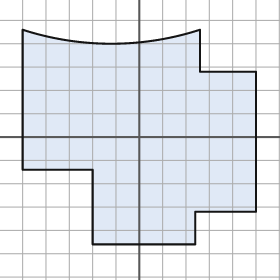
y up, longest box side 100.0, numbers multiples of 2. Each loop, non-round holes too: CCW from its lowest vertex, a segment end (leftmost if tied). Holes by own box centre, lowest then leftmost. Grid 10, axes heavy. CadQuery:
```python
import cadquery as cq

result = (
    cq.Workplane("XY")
    .moveTo(-20.0, -46.0)
    .lineTo(24.0, -46.0)
    .lineTo(24.0, -32.0)
    .lineTo(50.0, -32.0)
    .lineTo(50.0, 28.0)
    .lineTo(26.0, 28.0)
    .lineTo(26.0, 46.0)
    .threePointArc((-12.0, 40.0), (-50.0, 46.0))
    .lineTo(-50.0, -14.0)
    .lineTo(-20.0, -14.0)
    .close()
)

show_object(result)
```